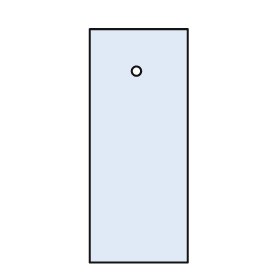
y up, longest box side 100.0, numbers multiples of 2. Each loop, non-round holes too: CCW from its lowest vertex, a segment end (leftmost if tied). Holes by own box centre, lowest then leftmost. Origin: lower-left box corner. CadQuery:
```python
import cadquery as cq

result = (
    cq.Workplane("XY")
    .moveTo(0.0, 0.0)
    .lineTo(42.0, 0.0)
    .lineTo(42.0, 100.0)
    .lineTo(0.0, 100.0)
    .close()
    .moveTo(20.0, 82.0)
    .circle(2.0)
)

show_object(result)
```